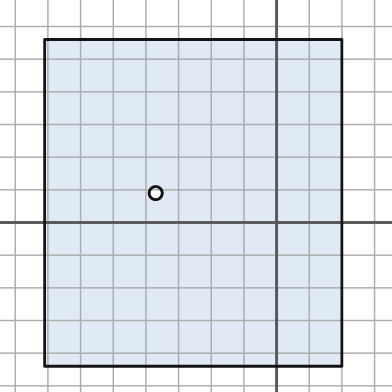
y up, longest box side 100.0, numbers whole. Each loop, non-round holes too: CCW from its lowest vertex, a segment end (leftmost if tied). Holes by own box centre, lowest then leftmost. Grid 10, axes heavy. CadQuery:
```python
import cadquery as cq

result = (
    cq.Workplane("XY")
    .moveTo(-71.0, -44.0)
    .lineTo(20.0, -44.0)
    .lineTo(20.0, 56.0)
    .lineTo(-71.0, 56.0)
    .close()
    .moveTo(-37.0, 9.0)
    .circle(2.0)
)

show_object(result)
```